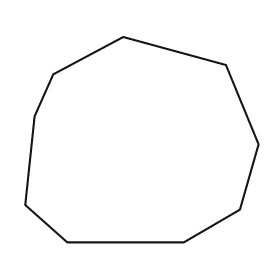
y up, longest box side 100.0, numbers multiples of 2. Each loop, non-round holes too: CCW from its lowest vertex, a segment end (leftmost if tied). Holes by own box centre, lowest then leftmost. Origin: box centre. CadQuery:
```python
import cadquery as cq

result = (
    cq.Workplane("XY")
    .moveTo(-32.0, -44.0)
    .lineTo(18.0, -44.0)
    .lineTo(42.0, -30.0)
    .lineTo(50.0, -2.0)
    .lineTo(36.0, 32.0)
    .lineTo(-8.0, 44.0)
    .lineTo(-38.0, 28.0)
    .lineTo(-46.0, 10.0)
    .lineTo(-50.0, -28.0)
    .close()
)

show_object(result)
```